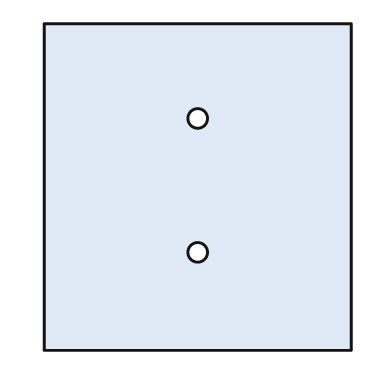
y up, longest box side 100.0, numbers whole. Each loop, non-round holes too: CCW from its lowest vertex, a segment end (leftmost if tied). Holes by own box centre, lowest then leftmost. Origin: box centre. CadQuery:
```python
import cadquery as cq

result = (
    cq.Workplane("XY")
    .moveTo(-47.0, -50.0)
    .lineTo(47.0, -50.0)
    .lineTo(47.0, 50.0)
    .lineTo(-47.0, 50.0)
    .close()
    .moveTo(0.0, -20.0)
    .circle(3.0)
    .moveTo(0.0, 21.0)
    .circle(3.0)
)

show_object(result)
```